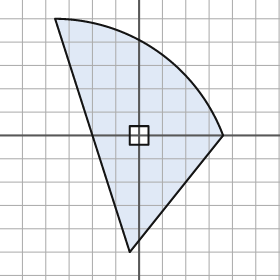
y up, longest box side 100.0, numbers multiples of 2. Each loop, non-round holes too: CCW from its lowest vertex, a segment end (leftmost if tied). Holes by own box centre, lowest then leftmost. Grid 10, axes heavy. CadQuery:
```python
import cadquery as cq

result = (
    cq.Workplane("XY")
    .moveTo(-4.0, -50.0)
    .lineTo(36.0, 0.0)
    .threePointArc((8.0, 36.0), (-36.0, 50.0))
    .close()
    .moveTo(-4.0, -4.0)
    .lineTo(4.0, -4.0)
    .lineTo(4.0, 4.0)
    .lineTo(-4.0, 4.0)
    .close()
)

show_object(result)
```